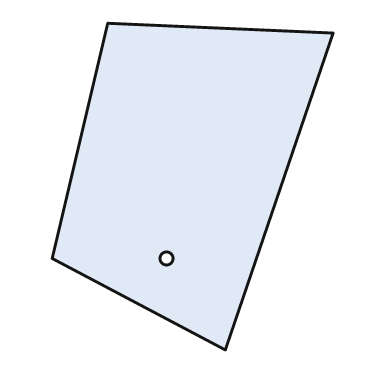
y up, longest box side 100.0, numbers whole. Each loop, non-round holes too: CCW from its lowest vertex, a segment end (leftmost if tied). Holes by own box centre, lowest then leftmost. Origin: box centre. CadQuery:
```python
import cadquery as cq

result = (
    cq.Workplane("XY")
    .moveTo(10.0, -50.0)
    .lineTo(43.0, 47.0)
    .lineTo(-26.0, 50.0)
    .lineTo(-43.0, -22.0)
    .close()
    .moveTo(-8.0, -22.0)
    .circle(2.0)
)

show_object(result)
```